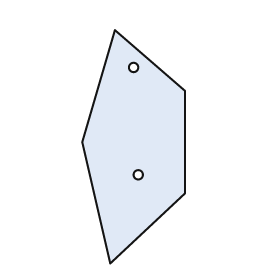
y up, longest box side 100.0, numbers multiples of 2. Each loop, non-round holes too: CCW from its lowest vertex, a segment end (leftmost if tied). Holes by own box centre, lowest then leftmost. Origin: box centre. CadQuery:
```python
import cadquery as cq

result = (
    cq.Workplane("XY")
    .moveTo(-10.0, -50.0)
    .lineTo(22.0, -20.0)
    .lineTo(22.0, 24.0)
    .lineTo(-8.0, 50.0)
    .lineTo(-22.0, 2.0)
    .close()
    .moveTo(2.0, -12.0)
    .circle(2.0)
    .moveTo(0.0, 34.0)
    .circle(2.0)
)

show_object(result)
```